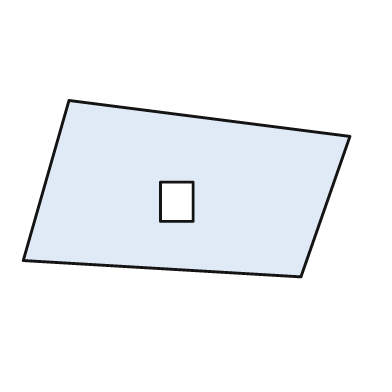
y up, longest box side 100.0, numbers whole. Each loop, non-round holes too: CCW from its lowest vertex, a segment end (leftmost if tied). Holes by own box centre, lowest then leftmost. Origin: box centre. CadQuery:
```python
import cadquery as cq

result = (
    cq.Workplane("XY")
    .moveTo(35.0, -27.0)
    .lineTo(50.0, 16.0)
    .lineTo(-36.0, 27.0)
    .lineTo(-50.0, -22.0)
    .close()
    .moveTo(-8.0, -10.0)
    .lineTo(2.0, -10.0)
    .lineTo(2.0, 2.0)
    .lineTo(-8.0, 2.0)
    .close()
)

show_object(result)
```